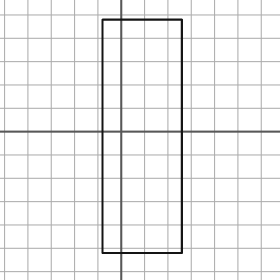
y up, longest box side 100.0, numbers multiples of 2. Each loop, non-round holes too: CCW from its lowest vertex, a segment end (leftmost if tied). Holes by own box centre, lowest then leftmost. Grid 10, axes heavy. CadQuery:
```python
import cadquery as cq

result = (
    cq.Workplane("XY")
    .moveTo(-8.0, -52.0)
    .lineTo(26.0, -52.0)
    .lineTo(26.0, 48.0)
    .lineTo(-8.0, 48.0)
    .close()
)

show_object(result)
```